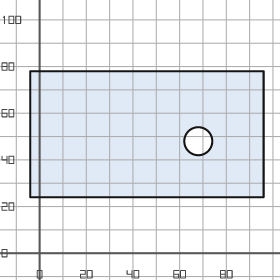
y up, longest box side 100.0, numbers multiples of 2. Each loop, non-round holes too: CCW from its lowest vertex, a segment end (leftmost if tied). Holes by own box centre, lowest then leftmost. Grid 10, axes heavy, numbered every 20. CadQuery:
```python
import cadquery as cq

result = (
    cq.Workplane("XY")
    .moveTo(-4.0, 24.0)
    .lineTo(96.0, 24.0)
    .lineTo(96.0, 78.0)
    .lineTo(-4.0, 78.0)
    .close()
    .moveTo(68.0, 48.0)
    .circle(6.0)
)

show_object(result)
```